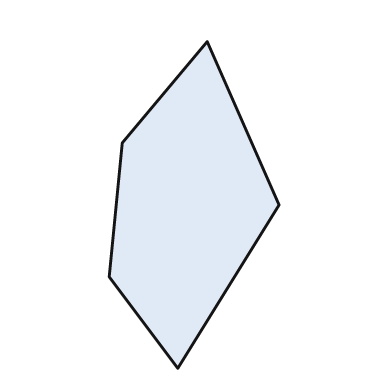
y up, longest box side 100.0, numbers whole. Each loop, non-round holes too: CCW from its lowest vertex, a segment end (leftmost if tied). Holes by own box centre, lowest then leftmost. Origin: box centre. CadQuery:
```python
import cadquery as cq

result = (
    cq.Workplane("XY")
    .moveTo(-5.0, -50.0)
    .lineTo(26.0, 0.0)
    .lineTo(4.0, 50.0)
    .lineTo(-22.0, 19.0)
    .lineTo(-26.0, -22.0)
    .close()
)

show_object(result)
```